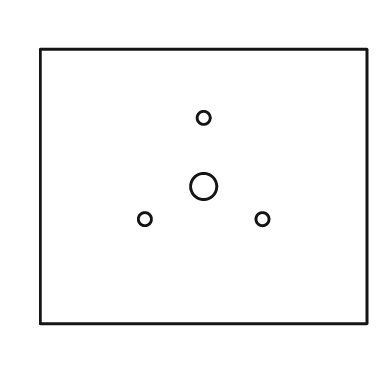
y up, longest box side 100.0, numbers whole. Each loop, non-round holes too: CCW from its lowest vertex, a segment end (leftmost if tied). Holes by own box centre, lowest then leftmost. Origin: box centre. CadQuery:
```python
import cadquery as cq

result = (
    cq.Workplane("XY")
    .moveTo(-50.0, -42.0)
    .lineTo(50.0, -42.0)
    .lineTo(50.0, 42.0)
    .lineTo(-50.0, 42.0)
    .close()
    .moveTo(-18.0, -10.0)
    .circle(2.0)
    .moveTo(18.0, -10.0)
    .circle(2.0)
    .moveTo(0.0, 0.0)
    .circle(4.0)
    .moveTo(0.0, 21.0)
    .circle(2.0)
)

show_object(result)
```